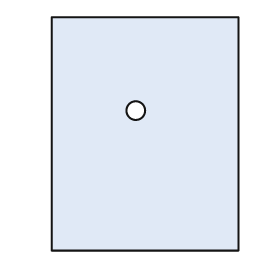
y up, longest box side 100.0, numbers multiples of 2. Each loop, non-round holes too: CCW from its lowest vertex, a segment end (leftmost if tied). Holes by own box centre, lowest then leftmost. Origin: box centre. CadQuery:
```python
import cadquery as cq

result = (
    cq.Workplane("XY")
    .moveTo(-40.0, -50.0)
    .lineTo(40.0, -50.0)
    .lineTo(40.0, 50.0)
    .lineTo(-40.0, 50.0)
    .close()
    .moveTo(-4.0, 10.0)
    .circle(4.0)
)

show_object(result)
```